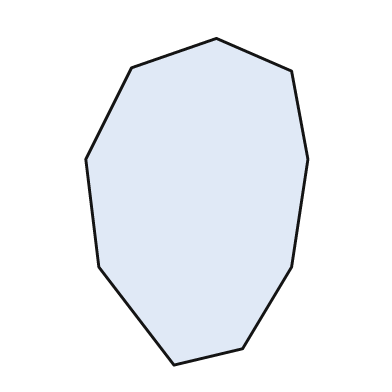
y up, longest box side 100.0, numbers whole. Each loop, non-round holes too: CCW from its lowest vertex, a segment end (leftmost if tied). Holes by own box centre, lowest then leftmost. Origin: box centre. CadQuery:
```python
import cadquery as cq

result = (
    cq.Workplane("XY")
    .moveTo(-7.0, -50.0)
    .lineTo(14.0, -45.0)
    .lineTo(29.0, -20.0)
    .lineTo(34.0, 13.0)
    .lineTo(29.0, 40.0)
    .lineTo(6.0, 50.0)
    .lineTo(-20.0, 41.0)
    .lineTo(-34.0, 13.0)
    .lineTo(-30.0, -20.0)
    .close()
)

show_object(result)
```